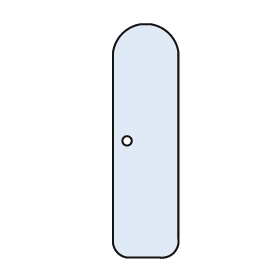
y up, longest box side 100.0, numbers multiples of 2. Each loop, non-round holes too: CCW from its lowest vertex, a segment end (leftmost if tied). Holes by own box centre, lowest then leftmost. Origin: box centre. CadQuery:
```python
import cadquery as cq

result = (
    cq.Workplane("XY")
    .moveTo(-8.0, -50.0)
    .lineTo(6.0, -50.0)
    .threePointArc((12.0, -48.0), (14.0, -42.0))
    .lineTo(14.0, 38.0)
    .threePointArc((10.0, 46.0), (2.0, 50.0))
    .lineTo(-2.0, 50.0)
    .threePointArc((-10.0, 46.0), (-14.0, 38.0))
    .lineTo(-14.0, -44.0)
    .threePointArc((-12.0, -48.0), (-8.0, -50.0))
    .close()
    .moveTo(-8.0, 0.0)
    .circle(2.0)
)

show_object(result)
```